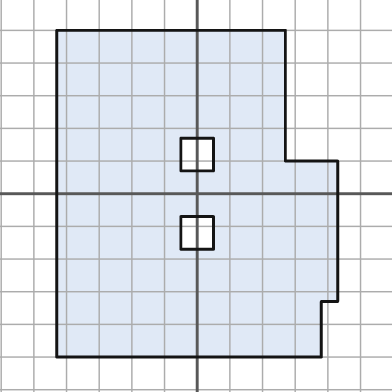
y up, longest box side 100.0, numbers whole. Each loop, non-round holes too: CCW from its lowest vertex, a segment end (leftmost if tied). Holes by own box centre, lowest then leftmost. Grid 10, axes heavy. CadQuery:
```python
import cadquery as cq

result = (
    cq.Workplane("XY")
    .moveTo(-43.0, -50.0)
    .lineTo(38.0, -50.0)
    .lineTo(38.0, -33.0)
    .lineTo(43.0, -33.0)
    .lineTo(43.0, 10.0)
    .lineTo(27.0, 10.0)
    .lineTo(27.0, 50.0)
    .lineTo(-43.0, 50.0)
    .close()
    .moveTo(-5.0, -17.0)
    .lineTo(5.0, -17.0)
    .lineTo(5.0, -7.0)
    .lineTo(-5.0, -7.0)
    .close()
    .moveTo(-5.0, 7.0)
    .lineTo(5.0, 7.0)
    .lineTo(5.0, 17.0)
    .lineTo(-5.0, 17.0)
    .close()
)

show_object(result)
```